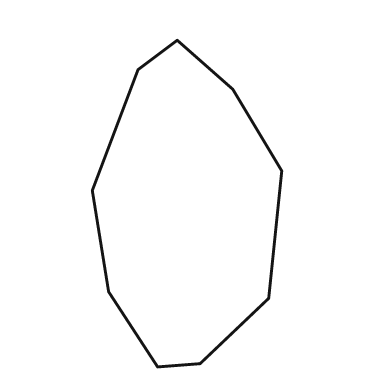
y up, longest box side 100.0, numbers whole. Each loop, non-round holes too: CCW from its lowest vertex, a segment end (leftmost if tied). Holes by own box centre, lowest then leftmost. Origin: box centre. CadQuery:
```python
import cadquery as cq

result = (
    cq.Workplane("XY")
    .moveTo(-9.0, -50.0)
    .lineTo(4.0, -49.0)
    .lineTo(25.0, -29.0)
    .lineTo(29.0, 10.0)
    .lineTo(14.0, 35.0)
    .lineTo(-3.0, 50.0)
    .lineTo(-15.0, 41.0)
    .lineTo(-29.0, 4.0)
    .lineTo(-24.0, -27.0)
    .close()
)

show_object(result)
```